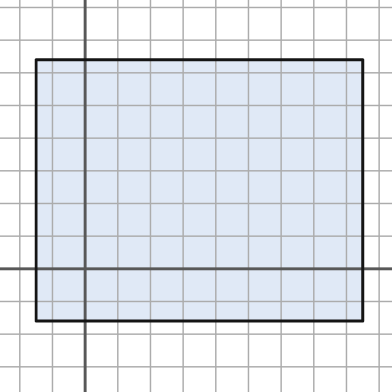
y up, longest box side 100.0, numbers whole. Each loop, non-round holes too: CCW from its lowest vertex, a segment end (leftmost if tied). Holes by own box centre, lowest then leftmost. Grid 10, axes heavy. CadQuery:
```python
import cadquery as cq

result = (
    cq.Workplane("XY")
    .moveTo(-15.0, -16.0)
    .lineTo(85.0, -16.0)
    .lineTo(85.0, 64.0)
    .lineTo(-15.0, 64.0)
    .close()
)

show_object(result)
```